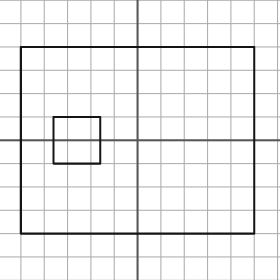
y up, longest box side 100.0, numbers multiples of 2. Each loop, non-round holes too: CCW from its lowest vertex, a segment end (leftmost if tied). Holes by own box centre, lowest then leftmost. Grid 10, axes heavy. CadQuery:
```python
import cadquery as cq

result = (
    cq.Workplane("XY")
    .moveTo(-50.0, -40.0)
    .lineTo(50.0, -40.0)
    .lineTo(50.0, 40.0)
    .lineTo(-50.0, 40.0)
    .close()
    .moveTo(-36.0, -10.0)
    .lineTo(-16.0, -10.0)
    .lineTo(-16.0, 10.0)
    .lineTo(-36.0, 10.0)
    .close()
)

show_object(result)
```